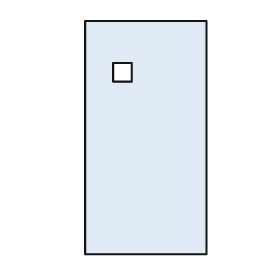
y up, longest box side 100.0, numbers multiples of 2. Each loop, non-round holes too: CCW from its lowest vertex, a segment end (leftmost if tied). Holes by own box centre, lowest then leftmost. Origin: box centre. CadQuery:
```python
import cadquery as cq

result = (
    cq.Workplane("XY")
    .moveTo(-26.0, -50.0)
    .lineTo(26.0, -50.0)
    .lineTo(26.0, 50.0)
    .lineTo(-26.0, 50.0)
    .close()
    .moveTo(-14.0, 24.0)
    .lineTo(-6.0, 24.0)
    .lineTo(-6.0, 32.0)
    .lineTo(-14.0, 32.0)
    .close()
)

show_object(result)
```